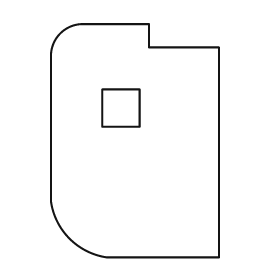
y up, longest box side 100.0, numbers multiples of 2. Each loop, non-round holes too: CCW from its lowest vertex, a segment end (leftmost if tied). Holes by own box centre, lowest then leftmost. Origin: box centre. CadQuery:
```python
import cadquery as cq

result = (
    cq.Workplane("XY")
    .moveTo(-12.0, -50.0)
    .lineTo(36.0, -50.0)
    .lineTo(36.0, 40.0)
    .lineTo(6.0, 40.0)
    .lineTo(6.0, 50.0)
    .lineTo(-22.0, 50.0)
    .threePointArc((-32.0, 46.0), (-36.0, 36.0))
    .lineTo(-36.0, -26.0)
    .threePointArc((-28.0, -42.0), (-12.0, -50.0))
    .close()
    .moveTo(-14.0, 6.0)
    .lineTo(2.0, 6.0)
    .lineTo(2.0, 22.0)
    .lineTo(-14.0, 22.0)
    .close()
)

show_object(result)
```